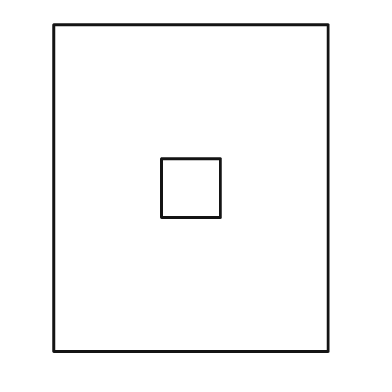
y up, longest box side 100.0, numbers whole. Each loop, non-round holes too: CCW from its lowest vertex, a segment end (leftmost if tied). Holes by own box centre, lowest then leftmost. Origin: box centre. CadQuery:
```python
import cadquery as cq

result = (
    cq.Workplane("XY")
    .moveTo(-42.0, -50.0)
    .lineTo(42.0, -50.0)
    .lineTo(42.0, 50.0)
    .lineTo(-42.0, 50.0)
    .close()
    .moveTo(-9.0, -9.0)
    .lineTo(9.0, -9.0)
    .lineTo(9.0, 9.0)
    .lineTo(-9.0, 9.0)
    .close()
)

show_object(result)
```